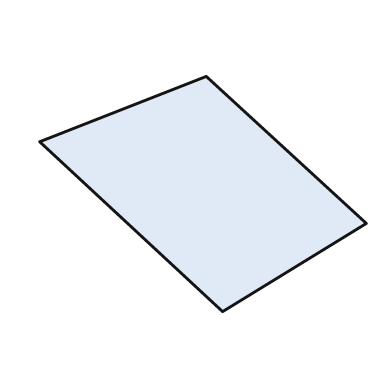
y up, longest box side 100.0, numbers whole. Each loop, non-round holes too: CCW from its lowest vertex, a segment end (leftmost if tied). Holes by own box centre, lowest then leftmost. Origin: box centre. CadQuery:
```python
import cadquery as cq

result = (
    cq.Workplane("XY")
    .moveTo(6.0, -36.0)
    .lineTo(50.0, -9.0)
    .lineTo(1.0, 36.0)
    .lineTo(-50.0, 16.0)
    .close()
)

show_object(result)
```